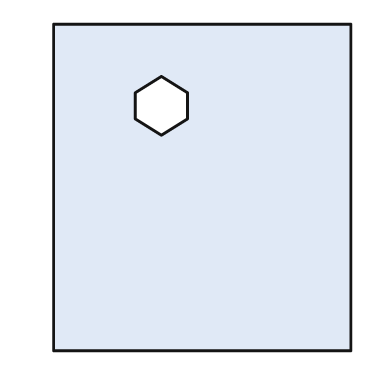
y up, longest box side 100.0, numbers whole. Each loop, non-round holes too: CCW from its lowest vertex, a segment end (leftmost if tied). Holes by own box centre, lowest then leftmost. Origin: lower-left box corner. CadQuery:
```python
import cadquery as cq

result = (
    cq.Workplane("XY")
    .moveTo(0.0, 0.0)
    .lineTo(91.0, 0.0)
    .lineTo(91.0, 100.0)
    .lineTo(0.0, 100.0)
    .close()
    .moveTo(33.0, 66.0)
    .lineTo(41.0, 71.0)
    .lineTo(41.0, 79.0)
    .lineTo(33.0, 84.0)
    .lineTo(25.0, 79.0)
    .lineTo(25.0, 71.0)
    .close()
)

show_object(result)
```